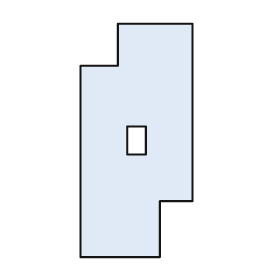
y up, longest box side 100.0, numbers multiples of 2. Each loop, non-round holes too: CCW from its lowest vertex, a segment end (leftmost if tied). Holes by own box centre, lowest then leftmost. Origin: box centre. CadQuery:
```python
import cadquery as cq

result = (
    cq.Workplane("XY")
    .moveTo(-24.0, -50.0)
    .lineTo(10.0, -50.0)
    .lineTo(10.0, -26.0)
    .lineTo(24.0, -26.0)
    .lineTo(24.0, 50.0)
    .lineTo(-8.0, 50.0)
    .lineTo(-8.0, 32.0)
    .lineTo(-24.0, 32.0)
    .close()
    .moveTo(-4.0, -6.0)
    .lineTo(4.0, -6.0)
    .lineTo(4.0, 6.0)
    .lineTo(-4.0, 6.0)
    .close()
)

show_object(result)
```